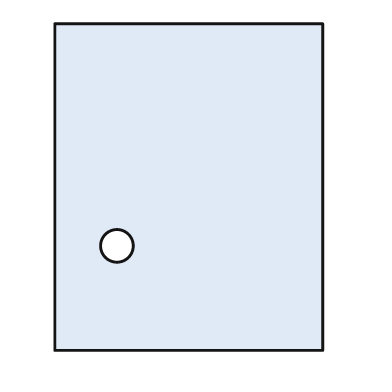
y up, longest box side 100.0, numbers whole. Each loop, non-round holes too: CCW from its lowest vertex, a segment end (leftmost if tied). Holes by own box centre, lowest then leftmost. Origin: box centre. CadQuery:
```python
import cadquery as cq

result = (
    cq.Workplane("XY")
    .moveTo(-41.0, -50.0)
    .lineTo(41.0, -50.0)
    .lineTo(41.0, 50.0)
    .lineTo(-41.0, 50.0)
    .close()
    .moveTo(-22.0, -18.0)
    .circle(5.0)
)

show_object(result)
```